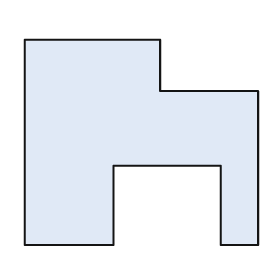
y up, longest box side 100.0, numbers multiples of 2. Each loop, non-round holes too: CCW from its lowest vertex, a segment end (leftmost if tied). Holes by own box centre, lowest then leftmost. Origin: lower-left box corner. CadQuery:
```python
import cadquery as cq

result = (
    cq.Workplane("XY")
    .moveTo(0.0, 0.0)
    .lineTo(38.0, 0.0)
    .lineTo(38.0, 34.0)
    .lineTo(84.0, 34.0)
    .lineTo(84.0, 0.0)
    .lineTo(100.0, 0.0)
    .lineTo(100.0, 66.0)
    .lineTo(58.0, 66.0)
    .lineTo(58.0, 88.0)
    .lineTo(0.0, 88.0)
    .close()
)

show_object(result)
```